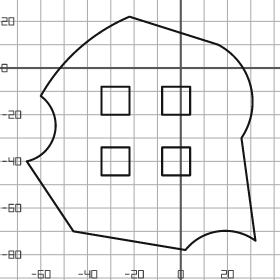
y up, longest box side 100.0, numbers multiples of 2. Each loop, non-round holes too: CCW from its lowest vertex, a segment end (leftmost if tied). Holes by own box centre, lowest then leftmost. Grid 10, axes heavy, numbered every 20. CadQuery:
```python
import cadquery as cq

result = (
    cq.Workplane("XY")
    .moveTo(2.0, -78.0)
    .threePointArc((16.0, -70.0), (32.0, -74.0))
    .lineTo(26.0, -30.0)
    .threePointArc((30.0, -8.0), (16.0, 10.0))
    .lineTo(-22.0, 22.0)
    .threePointArc((-44.0, 8.0), (-60.0, -12.0))
    .threePointArc((-54.0, -28.0), (-66.0, -40.0))
    .lineTo(-46.0, -70.0)
    .close()
    .moveTo(-34.0, -46.0)
    .lineTo(-22.0, -46.0)
    .lineTo(-22.0, -34.0)
    .lineTo(-34.0, -34.0)
    .close()
    .moveTo(-8.0, -46.0)
    .lineTo(4.0, -46.0)
    .lineTo(4.0, -34.0)
    .lineTo(-8.0, -34.0)
    .close()
    .moveTo(-34.0, -20.0)
    .lineTo(-22.0, -20.0)
    .lineTo(-22.0, -8.0)
    .lineTo(-34.0, -8.0)
    .close()
    .moveTo(-8.0, -20.0)
    .lineTo(4.0, -20.0)
    .lineTo(4.0, -8.0)
    .lineTo(-8.0, -8.0)
    .close()
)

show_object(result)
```